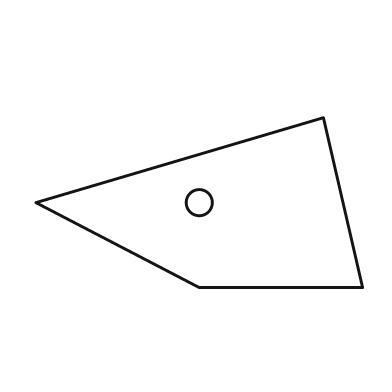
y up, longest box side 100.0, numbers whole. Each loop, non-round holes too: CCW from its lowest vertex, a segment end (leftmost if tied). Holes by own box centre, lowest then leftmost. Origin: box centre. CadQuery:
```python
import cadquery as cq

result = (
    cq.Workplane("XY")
    .moveTo(0.0, -26.0)
    .lineTo(50.0, -26.0)
    .lineTo(38.0, 26.0)
    .lineTo(-50.0, 0.0)
    .close()
    .moveTo(0.0, 0.0)
    .circle(4.0)
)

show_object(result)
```